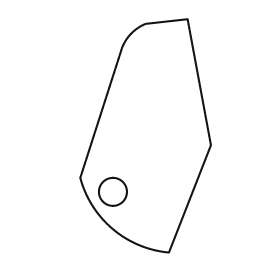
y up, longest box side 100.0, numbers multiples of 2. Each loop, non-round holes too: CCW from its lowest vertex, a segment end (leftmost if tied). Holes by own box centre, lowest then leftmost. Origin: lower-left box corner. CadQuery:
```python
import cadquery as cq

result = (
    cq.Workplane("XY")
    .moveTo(38.0, 0.0)
    .lineTo(56.0, 46.0)
    .lineTo(46.0, 100.0)
    .lineTo(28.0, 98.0)
    .threePointArc((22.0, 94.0), (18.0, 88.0))
    .lineTo(0.0, 32.0)
    .threePointArc((14.0, 10.0), (38.0, 0.0))
    .close()
    .moveTo(14.0, 26.0)
    .circle(6.0)
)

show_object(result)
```